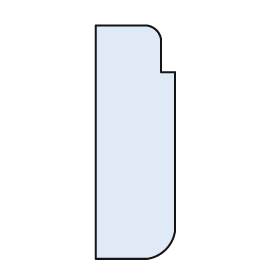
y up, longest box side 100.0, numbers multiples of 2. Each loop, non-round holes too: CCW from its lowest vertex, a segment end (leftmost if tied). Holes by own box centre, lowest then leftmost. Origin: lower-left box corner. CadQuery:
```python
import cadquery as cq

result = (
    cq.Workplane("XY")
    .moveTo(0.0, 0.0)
    .lineTo(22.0, 0.0)
    .threePointArc((30.0, 4.0), (34.0, 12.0))
    .lineTo(34.0, 80.0)
    .lineTo(28.0, 80.0)
    .lineTo(28.0, 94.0)
    .threePointArc((26.0, 98.0), (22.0, 100.0))
    .lineTo(0.0, 100.0)
    .close()
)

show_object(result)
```